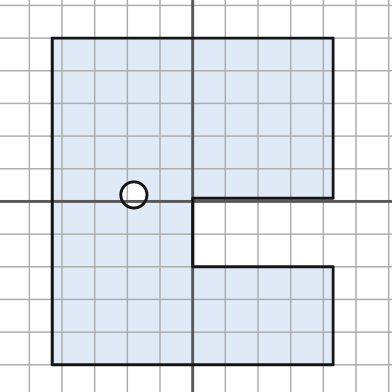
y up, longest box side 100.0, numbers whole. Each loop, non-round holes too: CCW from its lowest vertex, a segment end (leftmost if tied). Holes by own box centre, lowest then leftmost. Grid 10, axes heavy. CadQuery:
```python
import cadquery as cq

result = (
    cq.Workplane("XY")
    .moveTo(-43.0, -50.0)
    .lineTo(43.0, -50.0)
    .lineTo(43.0, -20.0)
    .lineTo(0.0, -20.0)
    .lineTo(0.0, 1.0)
    .lineTo(43.0, 1.0)
    .lineTo(43.0, 50.0)
    .lineTo(-43.0, 50.0)
    .close()
    .moveTo(-18.0, 2.0)
    .circle(4.0)
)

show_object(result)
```